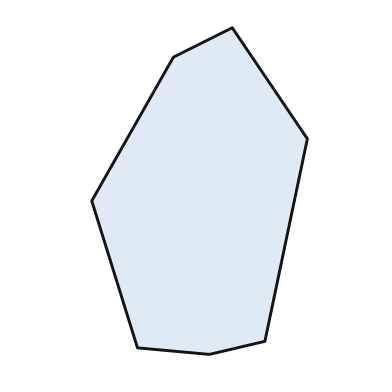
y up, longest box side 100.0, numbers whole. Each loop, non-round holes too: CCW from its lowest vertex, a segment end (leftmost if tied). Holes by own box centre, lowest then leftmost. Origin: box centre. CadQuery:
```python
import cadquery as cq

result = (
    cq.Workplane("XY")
    .moveTo(3.0, -50.0)
    .lineTo(20.0, -46.0)
    .lineTo(33.0, 16.0)
    .lineTo(10.0, 50.0)
    .lineTo(-8.0, 41.0)
    .lineTo(-33.0, -3.0)
    .lineTo(-19.0, -48.0)
    .close()
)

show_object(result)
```